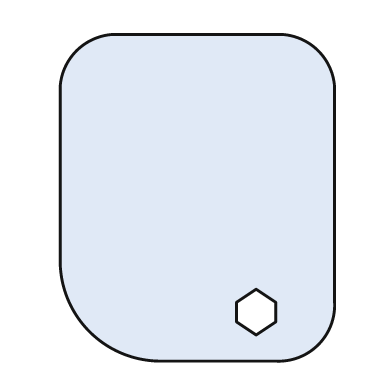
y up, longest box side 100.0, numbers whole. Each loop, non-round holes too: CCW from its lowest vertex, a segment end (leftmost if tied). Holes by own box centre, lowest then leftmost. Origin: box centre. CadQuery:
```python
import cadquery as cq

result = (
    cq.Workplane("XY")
    .moveTo(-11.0, -50.0)
    .lineTo(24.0, -50.0)
    .threePointArc((37.0, -45.0), (42.0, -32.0))
    .lineTo(42.0, 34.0)
    .threePointArc((37.0, 45.0), (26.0, 50.0))
    .lineTo(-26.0, 50.0)
    .threePointArc((-37.0, 45.0), (-42.0, 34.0))
    .lineTo(-42.0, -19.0)
    .threePointArc((-33.0, -41.0), (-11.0, -50.0))
    .close()
    .moveTo(18.0, -42.0)
    .lineTo(24.0, -38.0)
    .lineTo(24.0, -32.0)
    .lineTo(18.0, -28.0)
    .lineTo(12.0, -32.0)
    .lineTo(12.0, -38.0)
    .close()
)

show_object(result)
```